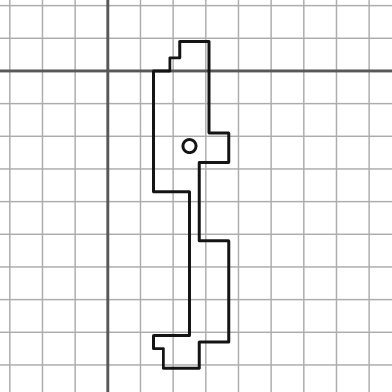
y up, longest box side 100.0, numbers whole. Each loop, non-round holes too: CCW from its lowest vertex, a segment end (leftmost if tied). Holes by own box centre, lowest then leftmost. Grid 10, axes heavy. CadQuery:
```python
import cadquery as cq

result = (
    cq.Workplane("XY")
    .moveTo(17.0, -91.0)
    .lineTo(28.0, -91.0)
    .lineTo(28.0, -83.0)
    .lineTo(37.0, -83.0)
    .lineTo(37.0, -52.0)
    .lineTo(28.0, -52.0)
    .lineTo(28.0, -28.0)
    .lineTo(37.0, -28.0)
    .lineTo(37.0, -19.0)
    .lineTo(31.0, -19.0)
    .lineTo(31.0, 9.0)
    .lineTo(22.0, 9.0)
    .lineTo(22.0, 4.0)
    .lineTo(19.0, 4.0)
    .lineTo(19.0, 0.0)
    .lineTo(14.0, 0.0)
    .lineTo(14.0, -37.0)
    .lineTo(25.0, -37.0)
    .lineTo(25.0, -81.0)
    .lineTo(14.0, -81.0)
    .lineTo(14.0, -85.0)
    .lineTo(17.0, -85.0)
    .close()
    .moveTo(25.0, -23.0)
    .circle(2.0)
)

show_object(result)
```